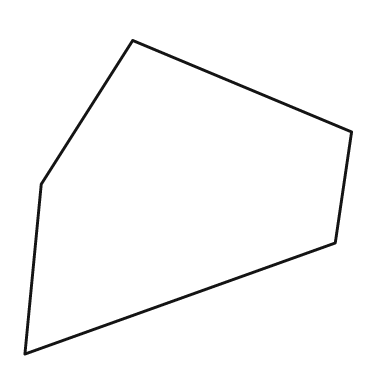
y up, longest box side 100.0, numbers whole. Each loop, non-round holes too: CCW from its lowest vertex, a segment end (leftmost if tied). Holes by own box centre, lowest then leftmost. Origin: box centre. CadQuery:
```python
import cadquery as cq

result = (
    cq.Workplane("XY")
    .moveTo(-50.0, -48.0)
    .lineTo(45.0, -14.0)
    .lineTo(50.0, 20.0)
    .lineTo(-17.0, 48.0)
    .lineTo(-45.0, 4.0)
    .close()
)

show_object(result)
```